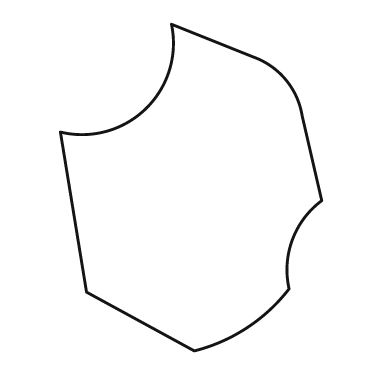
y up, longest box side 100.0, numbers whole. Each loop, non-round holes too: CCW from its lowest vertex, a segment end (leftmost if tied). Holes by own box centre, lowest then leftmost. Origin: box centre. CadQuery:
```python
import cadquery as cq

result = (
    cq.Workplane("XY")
    .moveTo(1.0, -50.0)
    .threePointArc((17.0, -43.0), (30.0, -31.0))
    .threePointArc((31.0, -16.0), (40.0, -4.0))
    .lineTo(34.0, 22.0)
    .threePointArc((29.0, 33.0), (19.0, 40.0))
    .lineTo(-6.0, 50.0)
    .threePointArc((-14.0, 24.0), (-40.0, 17.0))
    .lineTo(-32.0, -32.0)
    .close()
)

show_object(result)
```